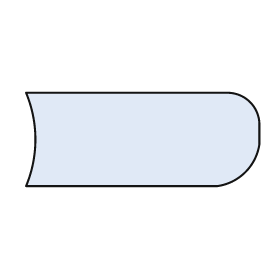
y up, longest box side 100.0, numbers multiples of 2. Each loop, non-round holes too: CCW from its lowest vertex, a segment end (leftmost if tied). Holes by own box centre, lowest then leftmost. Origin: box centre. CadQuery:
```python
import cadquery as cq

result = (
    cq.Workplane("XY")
    .moveTo(-50.0, -20.0)
    .lineTo(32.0, -20.0)
    .threePointArc((44.0, -14.0), (50.0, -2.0))
    .lineTo(50.0, 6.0)
    .threePointArc((46.0, 16.0), (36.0, 20.0))
    .lineTo(-50.0, 20.0)
    .threePointArc((-46.0, 0.0), (-50.0, -20.0))
    .close()
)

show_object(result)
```